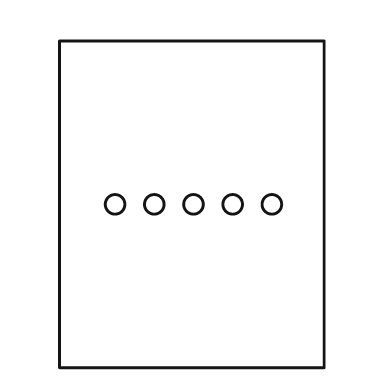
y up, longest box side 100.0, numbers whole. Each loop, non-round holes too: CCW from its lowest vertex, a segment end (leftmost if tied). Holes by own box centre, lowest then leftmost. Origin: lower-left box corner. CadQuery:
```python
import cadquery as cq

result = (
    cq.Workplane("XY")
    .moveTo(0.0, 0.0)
    .lineTo(81.0, 0.0)
    .lineTo(81.0, 100.0)
    .lineTo(0.0, 100.0)
    .close()
    .moveTo(17.0, 50.0)
    .circle(3.0)
    .moveTo(29.0, 50.0)
    .circle(3.0)
    .moveTo(41.0, 50.0)
    .circle(3.0)
    .moveTo(53.0, 50.0)
    .circle(3.0)
    .moveTo(65.0, 50.0)
    .circle(3.0)
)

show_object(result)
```